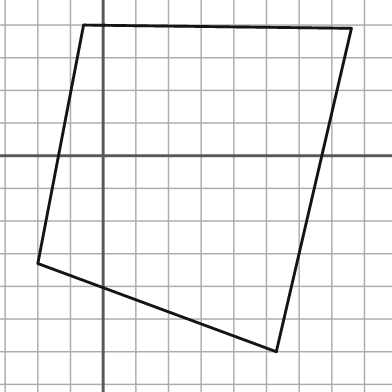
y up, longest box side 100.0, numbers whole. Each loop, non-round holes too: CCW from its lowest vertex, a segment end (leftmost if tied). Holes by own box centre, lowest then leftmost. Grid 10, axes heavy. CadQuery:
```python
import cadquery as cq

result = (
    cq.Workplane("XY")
    .moveTo(53.0, -60.0)
    .lineTo(76.0, 39.0)
    .lineTo(-6.0, 40.0)
    .lineTo(-20.0, -33.0)
    .close()
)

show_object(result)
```